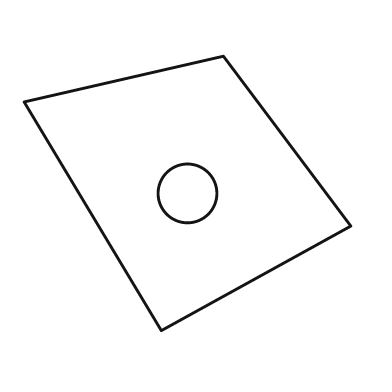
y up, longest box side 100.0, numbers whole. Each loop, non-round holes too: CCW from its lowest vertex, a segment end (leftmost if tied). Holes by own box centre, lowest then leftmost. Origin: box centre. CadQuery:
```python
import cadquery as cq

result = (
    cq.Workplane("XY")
    .moveTo(-8.0, -42.0)
    .lineTo(50.0, -10.0)
    .lineTo(11.0, 42.0)
    .lineTo(-50.0, 28.0)
    .close()
    .moveTo(0.0, 0.0)
    .circle(9.0)
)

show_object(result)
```